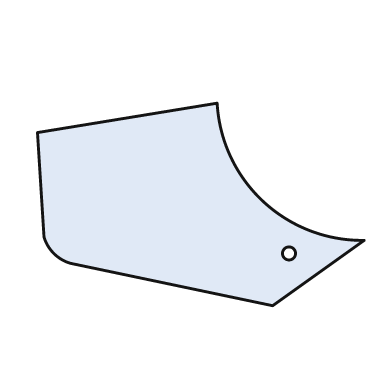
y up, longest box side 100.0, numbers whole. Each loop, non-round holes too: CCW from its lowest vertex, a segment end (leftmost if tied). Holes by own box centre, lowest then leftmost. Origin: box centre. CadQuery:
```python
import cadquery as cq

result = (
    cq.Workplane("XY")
    .moveTo(22.0, -31.0)
    .lineTo(50.0, -11.0)
    .threePointArc((19.0, 1.0), (5.0, 31.0))
    .lineTo(-50.0, 22.0)
    .lineTo(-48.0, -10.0)
    .threePointArc((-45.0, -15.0), (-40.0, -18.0))
    .close()
    .moveTo(27.0, -15.0)
    .circle(2.0)
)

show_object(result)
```